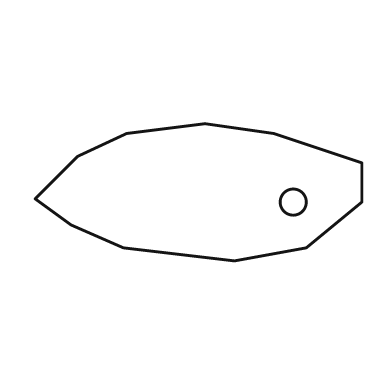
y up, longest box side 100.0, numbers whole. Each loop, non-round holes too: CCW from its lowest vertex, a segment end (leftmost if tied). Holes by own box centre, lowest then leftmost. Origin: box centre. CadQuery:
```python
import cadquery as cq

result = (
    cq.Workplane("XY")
    .moveTo(11.0, -21.0)
    .lineTo(33.0, -17.0)
    .lineTo(50.0, -3.0)
    .lineTo(50.0, 9.0)
    .lineTo(23.0, 18.0)
    .lineTo(2.0, 21.0)
    .lineTo(-22.0, 18.0)
    .lineTo(-37.0, 11.0)
    .lineTo(-50.0, -2.0)
    .lineTo(-39.0, -10.0)
    .lineTo(-23.0, -17.0)
    .close()
    .moveTo(29.0, -3.0)
    .circle(4.0)
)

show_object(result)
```